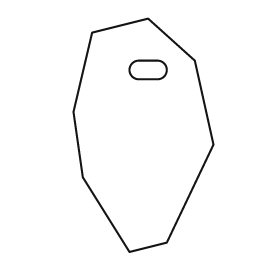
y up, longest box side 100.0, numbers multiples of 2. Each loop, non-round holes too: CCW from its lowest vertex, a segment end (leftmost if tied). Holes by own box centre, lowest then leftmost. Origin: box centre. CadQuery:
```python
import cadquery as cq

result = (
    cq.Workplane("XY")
    .moveTo(-6.0, -50.0)
    .lineTo(10.0, -46.0)
    .lineTo(30.0, -4.0)
    .lineTo(22.0, 32.0)
    .lineTo(2.0, 50.0)
    .lineTo(-22.0, 44.0)
    .lineTo(-30.0, 10.0)
    .lineTo(-26.0, -18.0)
    .close()
    .moveTo(-2.0, 24.0)
    .lineTo(6.0, 24.0)
    .threePointArc((10.0, 28.0), (6.0, 32.0))
    .lineTo(-2.0, 32.0)
    .threePointArc((-6.0, 28.0), (-2.0, 24.0))
    .close()
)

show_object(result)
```